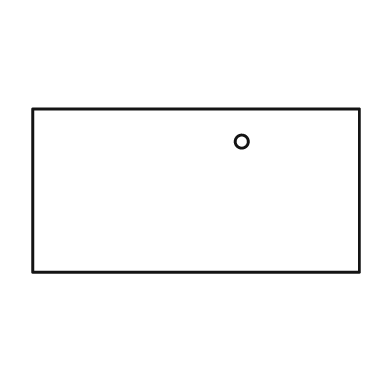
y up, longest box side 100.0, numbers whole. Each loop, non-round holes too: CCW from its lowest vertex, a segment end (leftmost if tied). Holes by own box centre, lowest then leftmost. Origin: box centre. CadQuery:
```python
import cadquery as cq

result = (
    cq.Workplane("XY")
    .moveTo(-50.0, -25.0)
    .lineTo(50.0, -25.0)
    .lineTo(50.0, 25.0)
    .lineTo(-50.0, 25.0)
    .close()
    .moveTo(14.0, 15.0)
    .circle(2.0)
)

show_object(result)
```